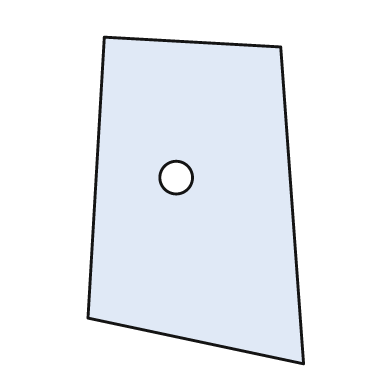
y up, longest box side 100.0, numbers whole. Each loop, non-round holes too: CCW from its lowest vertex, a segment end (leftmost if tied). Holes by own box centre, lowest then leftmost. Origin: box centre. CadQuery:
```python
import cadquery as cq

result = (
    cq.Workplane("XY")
    .moveTo(33.0, -50.0)
    .lineTo(26.0, 47.0)
    .lineTo(-28.0, 50.0)
    .lineTo(-33.0, -36.0)
    .close()
    .moveTo(-6.0, 7.0)
    .circle(5.0)
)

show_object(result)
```